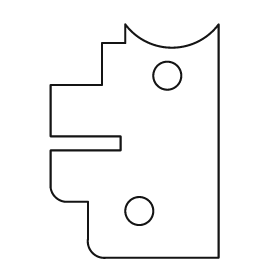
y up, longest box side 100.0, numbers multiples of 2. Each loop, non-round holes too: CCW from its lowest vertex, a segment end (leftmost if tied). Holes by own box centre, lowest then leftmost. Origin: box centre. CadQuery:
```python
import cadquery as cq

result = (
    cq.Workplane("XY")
    .moveTo(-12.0, -50.0)
    .lineTo(36.0, -50.0)
    .lineTo(36.0, 50.0)
    .threePointArc((16.0, 40.0), (-4.0, 50.0))
    .lineTo(-4.0, 42.0)
    .lineTo(-14.0, 42.0)
    .lineTo(-14.0, 24.0)
    .lineTo(-36.0, 24.0)
    .lineTo(-36.0, 2.0)
    .lineTo(-6.0, 2.0)
    .lineTo(-6.0, -4.0)
    .lineTo(-36.0, -4.0)
    .lineTo(-36.0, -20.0)
    .threePointArc((-34.0, -24.0), (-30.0, -26.0))
    .lineTo(-20.0, -26.0)
    .lineTo(-20.0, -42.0)
    .threePointArc((-18.0, -48.0), (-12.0, -50.0))
    .close()
    .moveTo(2.0, -30.0)
    .circle(6.0)
    .moveTo(14.0, 28.0)
    .circle(6.0)
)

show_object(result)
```